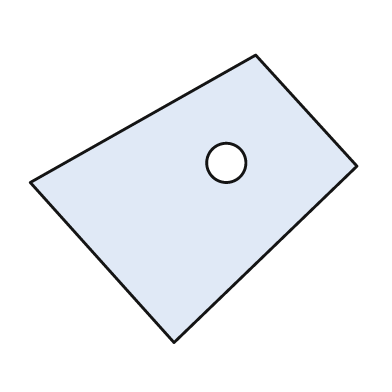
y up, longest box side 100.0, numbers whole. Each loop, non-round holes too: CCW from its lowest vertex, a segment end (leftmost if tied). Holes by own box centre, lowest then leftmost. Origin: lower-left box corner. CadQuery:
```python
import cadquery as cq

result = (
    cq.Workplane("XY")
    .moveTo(44.0, 0.0)
    .lineTo(100.0, 54.0)
    .lineTo(69.0, 88.0)
    .lineTo(0.0, 49.0)
    .close()
    .moveTo(60.0, 55.0)
    .circle(6.0)
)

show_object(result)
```